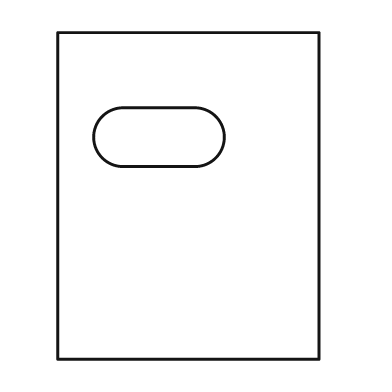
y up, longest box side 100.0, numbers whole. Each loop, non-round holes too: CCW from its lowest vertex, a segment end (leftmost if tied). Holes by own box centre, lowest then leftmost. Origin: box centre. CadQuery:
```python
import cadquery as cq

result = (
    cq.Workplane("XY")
    .moveTo(-40.0, -50.0)
    .lineTo(40.0, -50.0)
    .lineTo(40.0, 50.0)
    .lineTo(-40.0, 50.0)
    .close()
    .moveTo(-20.0, 9.0)
    .lineTo(2.0, 9.0)
    .threePointArc((11.0, 18.0), (2.0, 27.0))
    .lineTo(-20.0, 27.0)
    .threePointArc((-29.0, 18.0), (-20.0, 9.0))
    .close()
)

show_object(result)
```